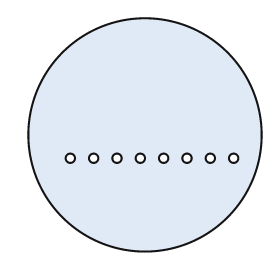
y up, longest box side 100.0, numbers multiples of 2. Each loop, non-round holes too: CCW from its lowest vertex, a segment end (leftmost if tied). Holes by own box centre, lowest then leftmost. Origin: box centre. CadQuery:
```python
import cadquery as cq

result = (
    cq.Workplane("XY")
    .moveTo(0.0, 0.0)
    .circle(50.0)
    .moveTo(-32.0, -10.0)
    .circle(2.0)
    .moveTo(-22.0, -10.0)
    .circle(2.0)
    .moveTo(-12.0, -10.0)
    .circle(2.0)
    .moveTo(-2.0, -10.0)
    .circle(2.0)
    .moveTo(8.0, -10.0)
    .circle(2.0)
    .moveTo(18.0, -10.0)
    .circle(2.0)
    .moveTo(28.0, -10.0)
    .circle(2.0)
    .moveTo(38.0, -10.0)
    .circle(2.0)
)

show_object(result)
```